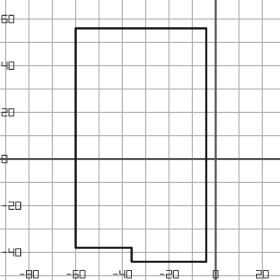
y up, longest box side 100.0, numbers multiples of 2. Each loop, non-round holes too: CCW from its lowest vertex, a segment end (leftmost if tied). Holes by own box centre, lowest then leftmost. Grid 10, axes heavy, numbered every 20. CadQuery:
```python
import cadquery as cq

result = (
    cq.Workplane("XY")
    .moveTo(-36.0, -44.0)
    .lineTo(-4.0, -44.0)
    .lineTo(-4.0, 56.0)
    .lineTo(-60.0, 56.0)
    .lineTo(-60.0, -38.0)
    .lineTo(-36.0, -38.0)
    .close()
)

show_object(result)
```